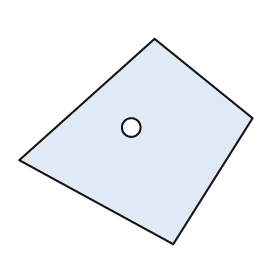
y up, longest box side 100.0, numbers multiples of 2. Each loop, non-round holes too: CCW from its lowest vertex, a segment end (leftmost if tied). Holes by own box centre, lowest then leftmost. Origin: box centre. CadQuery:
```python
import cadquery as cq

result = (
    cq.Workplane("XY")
    .moveTo(16.0, -44.0)
    .lineTo(50.0, 10.0)
    .lineTo(8.0, 44.0)
    .lineTo(-50.0, -8.0)
    .close()
    .moveTo(-2.0, 6.0)
    .circle(4.0)
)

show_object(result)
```